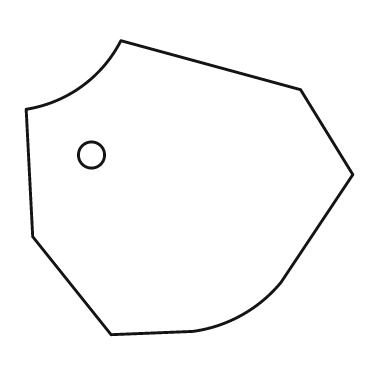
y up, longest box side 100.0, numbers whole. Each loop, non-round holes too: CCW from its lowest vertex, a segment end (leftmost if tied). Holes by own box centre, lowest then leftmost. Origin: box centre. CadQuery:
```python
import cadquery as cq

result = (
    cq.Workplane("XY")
    .moveTo(-24.0, -45.0)
    .lineTo(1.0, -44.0)
    .threePointArc((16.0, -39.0), (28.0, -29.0))
    .lineTo(50.0, 4.0)
    .lineTo(34.0, 30.0)
    .lineTo(-21.0, 45.0)
    .threePointArc((-33.0, 31.0), (-50.0, 24.0))
    .lineTo(-48.0, -15.0)
    .close()
    .moveTo(-30.0, 10.0)
    .circle(4.0)
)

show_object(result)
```